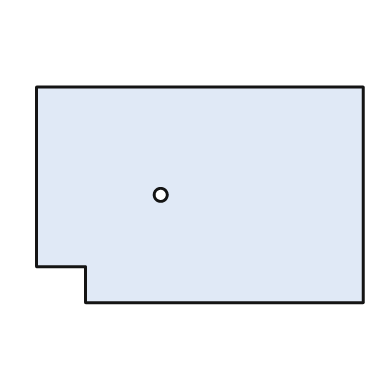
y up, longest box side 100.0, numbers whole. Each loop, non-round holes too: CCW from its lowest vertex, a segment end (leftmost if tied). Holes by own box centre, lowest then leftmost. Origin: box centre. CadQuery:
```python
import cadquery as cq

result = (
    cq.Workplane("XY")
    .moveTo(-35.0, -33.0)
    .lineTo(50.0, -33.0)
    .lineTo(50.0, 33.0)
    .lineTo(-50.0, 33.0)
    .lineTo(-50.0, -22.0)
    .lineTo(-35.0, -22.0)
    .close()
    .moveTo(-12.0, 0.0)
    .circle(2.0)
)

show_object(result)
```